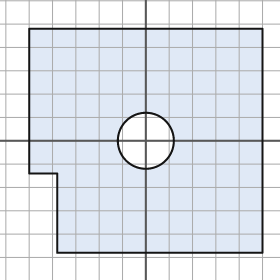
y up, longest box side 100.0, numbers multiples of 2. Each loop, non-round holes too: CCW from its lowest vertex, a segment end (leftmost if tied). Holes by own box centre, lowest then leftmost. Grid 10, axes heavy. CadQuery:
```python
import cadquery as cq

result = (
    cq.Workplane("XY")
    .moveTo(-38.0, -48.0)
    .lineTo(50.0, -48.0)
    .lineTo(50.0, 48.0)
    .lineTo(-50.0, 48.0)
    .lineTo(-50.0, -14.0)
    .lineTo(-38.0, -14.0)
    .close()
    .moveTo(0.0, 0.0)
    .circle(12.0)
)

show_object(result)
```